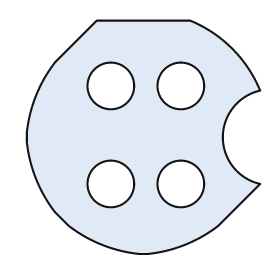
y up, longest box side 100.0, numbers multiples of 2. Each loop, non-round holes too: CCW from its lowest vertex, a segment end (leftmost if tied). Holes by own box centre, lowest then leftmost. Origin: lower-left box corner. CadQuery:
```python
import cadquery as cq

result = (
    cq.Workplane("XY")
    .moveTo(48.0, 0.0)
    .lineTo(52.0, 0.0)
    .threePointArc((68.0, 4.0), (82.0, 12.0))
    .lineTo(100.0, 30.0)
    .threePointArc((84.0, 50.0), (100.0, 70.0))
    .threePointArc((88.0, 88.0), (70.0, 100.0))
    .lineTo(30.0, 100.0)
    .lineTo(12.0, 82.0)
    .threePointArc((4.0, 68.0), (0.0, 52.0))
    .lineTo(0.0, 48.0)
    .threePointArc((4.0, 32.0), (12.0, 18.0))
    .lineTo(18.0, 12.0)
    .threePointArc((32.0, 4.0), (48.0, 0.0))
    .close()
    .moveTo(36.0, 30.0)
    .circle(10.0)
    .moveTo(66.0, 30.0)
    .circle(10.0)
    .moveTo(36.0, 72.0)
    .circle(10.0)
    .moveTo(66.0, 72.0)
    .circle(10.0)
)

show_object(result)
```